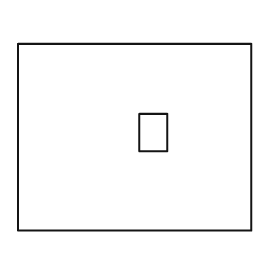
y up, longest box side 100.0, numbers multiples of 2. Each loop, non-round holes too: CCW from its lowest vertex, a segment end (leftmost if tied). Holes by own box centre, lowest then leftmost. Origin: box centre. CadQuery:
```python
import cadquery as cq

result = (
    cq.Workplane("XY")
    .moveTo(-50.0, -40.0)
    .lineTo(50.0, -40.0)
    .lineTo(50.0, 40.0)
    .lineTo(-50.0, 40.0)
    .close()
    .moveTo(2.0, -6.0)
    .lineTo(14.0, -6.0)
    .lineTo(14.0, 10.0)
    .lineTo(2.0, 10.0)
    .close()
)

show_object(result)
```